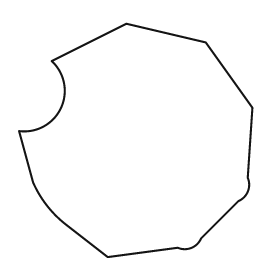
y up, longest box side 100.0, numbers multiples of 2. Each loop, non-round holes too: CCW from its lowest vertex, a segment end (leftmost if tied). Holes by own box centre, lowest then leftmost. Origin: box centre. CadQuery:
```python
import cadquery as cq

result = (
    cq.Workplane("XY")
    .moveTo(-12.0, -50.0)
    .lineTo(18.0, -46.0)
    .threePointArc((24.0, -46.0), (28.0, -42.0))
    .lineTo(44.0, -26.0)
    .threePointArc((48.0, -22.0), (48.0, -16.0))
    .lineTo(50.0, 14.0)
    .lineTo(30.0, 42.0)
    .lineTo(-4.0, 50.0)
    .lineTo(-36.0, 34.0)
    .threePointArc((-32.0, 14.0), (-50.0, 4.0))
    .lineTo(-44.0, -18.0)
    .threePointArc((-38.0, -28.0), (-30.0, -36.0))
    .close()
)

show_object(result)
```